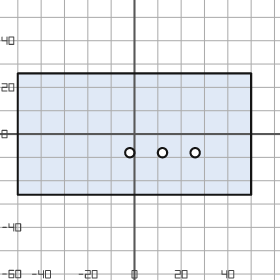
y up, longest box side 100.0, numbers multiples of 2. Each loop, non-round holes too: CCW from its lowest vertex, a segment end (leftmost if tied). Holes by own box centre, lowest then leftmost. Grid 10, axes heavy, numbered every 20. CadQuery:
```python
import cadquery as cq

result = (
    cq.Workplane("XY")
    .moveTo(-50.0, -26.0)
    .lineTo(50.0, -26.0)
    .lineTo(50.0, 26.0)
    .lineTo(-50.0, 26.0)
    .close()
    .moveTo(-2.0, -8.0)
    .circle(2.0)
    .moveTo(12.0, -8.0)
    .circle(2.0)
    .moveTo(26.0, -8.0)
    .circle(2.0)
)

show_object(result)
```